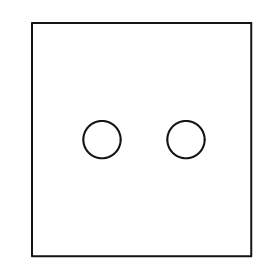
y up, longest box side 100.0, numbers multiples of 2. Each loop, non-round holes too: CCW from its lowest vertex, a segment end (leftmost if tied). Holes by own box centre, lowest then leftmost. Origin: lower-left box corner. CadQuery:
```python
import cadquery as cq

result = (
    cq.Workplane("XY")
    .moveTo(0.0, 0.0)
    .lineTo(94.0, 0.0)
    .lineTo(94.0, 100.0)
    .lineTo(0.0, 100.0)
    .close()
    .moveTo(30.0, 50.0)
    .circle(8.0)
    .moveTo(66.0, 50.0)
    .circle(8.0)
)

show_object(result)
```